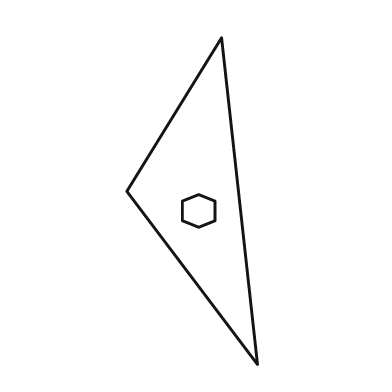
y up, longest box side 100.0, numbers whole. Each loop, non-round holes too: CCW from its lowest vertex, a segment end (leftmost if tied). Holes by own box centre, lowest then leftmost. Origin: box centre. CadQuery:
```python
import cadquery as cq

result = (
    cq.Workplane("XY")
    .moveTo(20.0, -50.0)
    .lineTo(9.0, 50.0)
    .lineTo(-20.0, 3.0)
    .close()
    .moveTo(2.0, -8.0)
    .lineTo(7.0, -6.0)
    .lineTo(7.0, 0.0)
    .lineTo(2.0, 2.0)
    .lineTo(-3.0, 0.0)
    .lineTo(-3.0, -6.0)
    .close()
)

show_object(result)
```